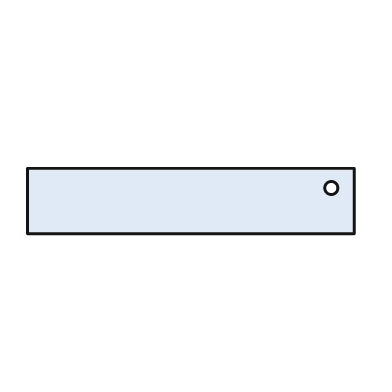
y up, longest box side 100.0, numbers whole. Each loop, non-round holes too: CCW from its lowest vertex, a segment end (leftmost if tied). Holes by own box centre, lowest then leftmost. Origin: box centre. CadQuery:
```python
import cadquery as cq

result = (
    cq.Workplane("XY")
    .moveTo(-50.0, -10.0)
    .lineTo(50.0, -10.0)
    .lineTo(50.0, 10.0)
    .lineTo(-50.0, 10.0)
    .close()
    .moveTo(43.0, 4.0)
    .circle(2.0)
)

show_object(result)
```